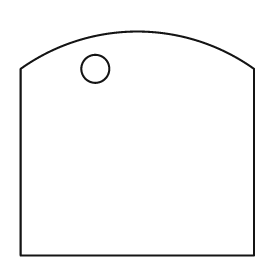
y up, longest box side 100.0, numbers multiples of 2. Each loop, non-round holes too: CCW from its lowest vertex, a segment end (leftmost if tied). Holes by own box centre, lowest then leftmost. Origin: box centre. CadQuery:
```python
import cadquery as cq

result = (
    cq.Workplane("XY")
    .moveTo(-50.0, -48.0)
    .lineTo(50.0, -48.0)
    .lineTo(50.0, 32.0)
    .threePointArc((0.0, 48.0), (-50.0, 32.0))
    .close()
    .moveTo(-18.0, 32.0)
    .circle(6.0)
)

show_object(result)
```